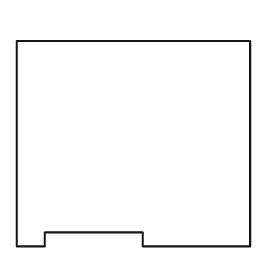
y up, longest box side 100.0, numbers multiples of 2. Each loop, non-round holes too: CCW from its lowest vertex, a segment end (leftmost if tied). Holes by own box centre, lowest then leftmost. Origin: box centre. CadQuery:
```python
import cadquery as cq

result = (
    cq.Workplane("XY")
    .moveTo(-50.0, -44.0)
    .lineTo(-38.0, -44.0)
    .lineTo(-38.0, -38.0)
    .lineTo(4.0, -38.0)
    .lineTo(4.0, -44.0)
    .lineTo(50.0, -44.0)
    .lineTo(50.0, 44.0)
    .lineTo(-50.0, 44.0)
    .close()
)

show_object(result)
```